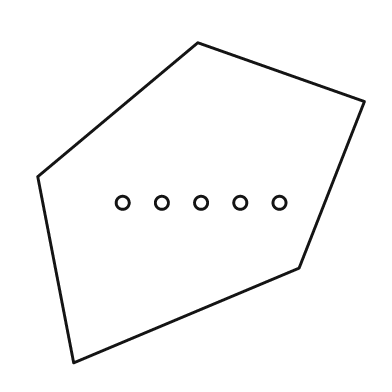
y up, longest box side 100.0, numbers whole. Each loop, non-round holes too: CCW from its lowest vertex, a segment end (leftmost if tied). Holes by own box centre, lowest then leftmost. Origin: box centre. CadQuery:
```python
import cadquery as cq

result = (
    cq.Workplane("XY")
    .moveTo(-39.0, -49.0)
    .lineTo(30.0, -20.0)
    .lineTo(50.0, 31.0)
    .lineTo(-1.0, 49.0)
    .lineTo(-50.0, 8.0)
    .close()
    .moveTo(-24.0, 0.0)
    .circle(2.0)
    .moveTo(-12.0, 0.0)
    .circle(2.0)
    .moveTo(0.0, 0.0)
    .circle(2.0)
    .moveTo(12.0, 0.0)
    .circle(2.0)
    .moveTo(24.0, 0.0)
    .circle(2.0)
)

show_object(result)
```